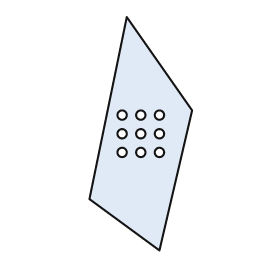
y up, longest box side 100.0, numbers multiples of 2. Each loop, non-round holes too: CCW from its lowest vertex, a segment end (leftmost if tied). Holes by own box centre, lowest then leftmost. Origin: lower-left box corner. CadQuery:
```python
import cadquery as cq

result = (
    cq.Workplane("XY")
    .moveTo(30.0, 0.0)
    .lineTo(44.0, 60.0)
    .lineTo(16.0, 100.0)
    .lineTo(0.0, 22.0)
    .close()
    .moveTo(14.0, 42.0)
    .circle(2.0)
    .moveTo(22.0, 42.0)
    .circle(2.0)
    .moveTo(30.0, 42.0)
    .circle(2.0)
    .moveTo(14.0, 50.0)
    .circle(2.0)
    .moveTo(22.0, 50.0)
    .circle(2.0)
    .moveTo(30.0, 50.0)
    .circle(2.0)
    .moveTo(14.0, 58.0)
    .circle(2.0)
    .moveTo(22.0, 58.0)
    .circle(2.0)
    .moveTo(30.0, 58.0)
    .circle(2.0)
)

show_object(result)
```